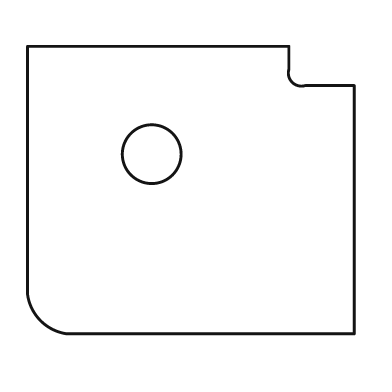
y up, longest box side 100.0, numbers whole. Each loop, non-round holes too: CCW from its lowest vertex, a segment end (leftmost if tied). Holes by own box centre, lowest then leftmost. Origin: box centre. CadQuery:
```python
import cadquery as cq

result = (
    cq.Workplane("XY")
    .moveTo(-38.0, -44.0)
    .lineTo(50.0, -44.0)
    .lineTo(50.0, 32.0)
    .lineTo(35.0, 32.0)
    .threePointArc((31.0, 33.0), (30.0, 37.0))
    .lineTo(30.0, 44.0)
    .lineTo(-50.0, 44.0)
    .lineTo(-50.0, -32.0)
    .threePointArc((-46.0, -40.0), (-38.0, -44.0))
    .close()
    .moveTo(-12.0, 11.0)
    .circle(9.0)
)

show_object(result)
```